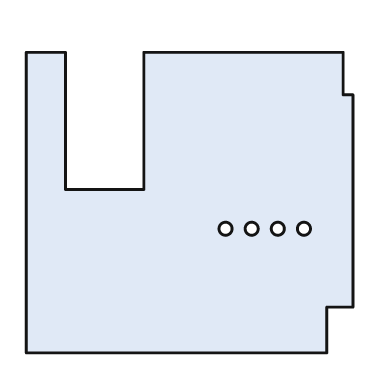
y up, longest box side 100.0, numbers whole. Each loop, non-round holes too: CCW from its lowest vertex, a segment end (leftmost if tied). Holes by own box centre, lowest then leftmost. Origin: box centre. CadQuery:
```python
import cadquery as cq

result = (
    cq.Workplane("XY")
    .moveTo(-50.0, -46.0)
    .lineTo(42.0, -46.0)
    .lineTo(42.0, -32.0)
    .lineTo(50.0, -32.0)
    .lineTo(50.0, 33.0)
    .lineTo(47.0, 33.0)
    .lineTo(47.0, 46.0)
    .lineTo(-14.0, 46.0)
    .lineTo(-14.0, 4.0)
    .lineTo(-38.0, 4.0)
    .lineTo(-38.0, 46.0)
    .lineTo(-50.0, 46.0)
    .close()
    .moveTo(11.0, -8.0)
    .circle(2.0)
    .moveTo(19.0, -8.0)
    .circle(2.0)
    .moveTo(27.0, -8.0)
    .circle(2.0)
    .moveTo(35.0, -8.0)
    .circle(2.0)
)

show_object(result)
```